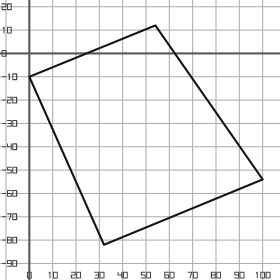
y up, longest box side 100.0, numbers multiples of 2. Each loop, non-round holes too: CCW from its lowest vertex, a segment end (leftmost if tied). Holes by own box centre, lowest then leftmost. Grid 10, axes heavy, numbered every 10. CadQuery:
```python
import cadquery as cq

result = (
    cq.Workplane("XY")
    .moveTo(32.0, -82.0)
    .lineTo(100.0, -54.0)
    .lineTo(54.0, 12.0)
    .lineTo(0.0, -10.0)
    .close()
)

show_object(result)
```